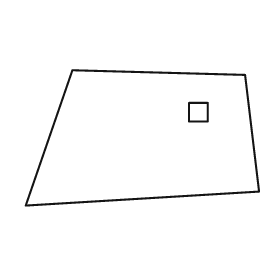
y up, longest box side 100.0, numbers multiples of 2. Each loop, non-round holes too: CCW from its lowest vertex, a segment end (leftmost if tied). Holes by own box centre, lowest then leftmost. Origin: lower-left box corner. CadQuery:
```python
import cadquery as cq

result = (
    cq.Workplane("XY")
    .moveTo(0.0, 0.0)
    .lineTo(100.0, 6.0)
    .lineTo(94.0, 56.0)
    .lineTo(20.0, 58.0)
    .close()
    .moveTo(70.0, 36.0)
    .lineTo(78.0, 36.0)
    .lineTo(78.0, 44.0)
    .lineTo(70.0, 44.0)
    .close()
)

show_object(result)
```